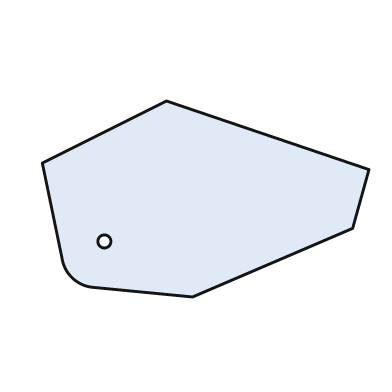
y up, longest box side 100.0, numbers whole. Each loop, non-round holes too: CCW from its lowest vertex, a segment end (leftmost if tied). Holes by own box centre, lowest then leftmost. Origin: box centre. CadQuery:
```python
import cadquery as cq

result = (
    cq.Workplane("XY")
    .moveTo(-4.0, -30.0)
    .lineTo(45.0, -9.0)
    .lineTo(50.0, 9.0)
    .lineTo(-12.0, 30.0)
    .lineTo(-50.0, 11.0)
    .lineTo(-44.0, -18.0)
    .threePointArc((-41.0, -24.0), (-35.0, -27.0))
    .close()
    .moveTo(-31.0, -13.0)
    .circle(2.0)
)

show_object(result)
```